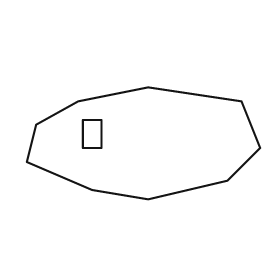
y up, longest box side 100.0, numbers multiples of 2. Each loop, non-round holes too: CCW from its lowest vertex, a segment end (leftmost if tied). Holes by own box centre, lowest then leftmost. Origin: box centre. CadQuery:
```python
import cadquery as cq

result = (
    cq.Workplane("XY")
    .moveTo(2.0, -24.0)
    .lineTo(36.0, -16.0)
    .lineTo(50.0, -2.0)
    .lineTo(42.0, 18.0)
    .lineTo(2.0, 24.0)
    .lineTo(-28.0, 18.0)
    .lineTo(-46.0, 8.0)
    .lineTo(-50.0, -8.0)
    .lineTo(-22.0, -20.0)
    .close()
    .moveTo(-26.0, -2.0)
    .lineTo(-18.0, -2.0)
    .lineTo(-18.0, 10.0)
    .lineTo(-26.0, 10.0)
    .close()
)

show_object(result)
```